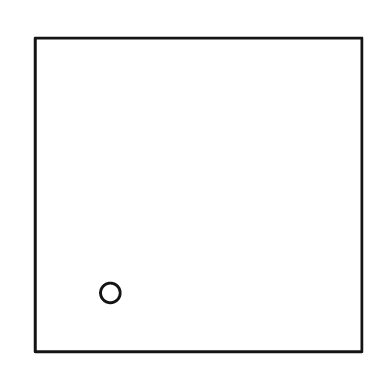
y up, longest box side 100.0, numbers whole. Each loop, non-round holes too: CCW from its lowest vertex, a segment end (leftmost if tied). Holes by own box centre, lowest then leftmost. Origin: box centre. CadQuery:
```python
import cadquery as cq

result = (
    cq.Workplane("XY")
    .moveTo(-50.0, -48.0)
    .lineTo(50.0, -48.0)
    .lineTo(50.0, 48.0)
    .lineTo(-50.0, 48.0)
    .close()
    .moveTo(-27.0, -30.0)
    .circle(3.0)
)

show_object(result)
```